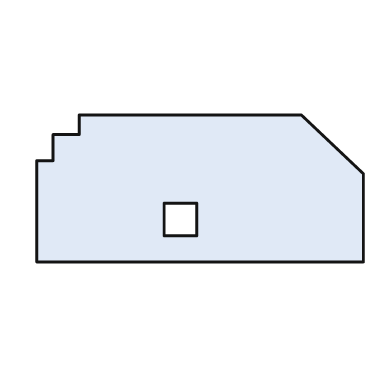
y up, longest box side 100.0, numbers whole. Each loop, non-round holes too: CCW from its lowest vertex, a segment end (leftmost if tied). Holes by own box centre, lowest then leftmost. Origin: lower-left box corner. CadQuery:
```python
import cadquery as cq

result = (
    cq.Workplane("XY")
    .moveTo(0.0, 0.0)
    .lineTo(100.0, 0.0)
    .lineTo(100.0, 27.0)
    .lineTo(81.0, 45.0)
    .lineTo(13.0, 45.0)
    .lineTo(13.0, 39.0)
    .lineTo(5.0, 39.0)
    .lineTo(5.0, 31.0)
    .lineTo(0.0, 31.0)
    .close()
    .moveTo(39.0, 8.0)
    .lineTo(49.0, 8.0)
    .lineTo(49.0, 18.0)
    .lineTo(39.0, 18.0)
    .close()
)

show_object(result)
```